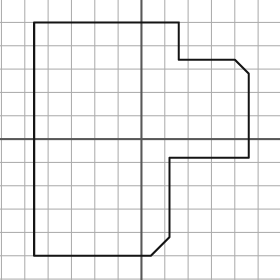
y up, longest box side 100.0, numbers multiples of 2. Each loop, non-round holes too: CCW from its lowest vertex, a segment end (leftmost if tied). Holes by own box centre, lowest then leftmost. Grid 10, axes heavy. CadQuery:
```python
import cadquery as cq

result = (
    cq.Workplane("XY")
    .moveTo(-46.0, -50.0)
    .lineTo(4.0, -50.0)
    .lineTo(12.0, -42.0)
    .lineTo(12.0, -8.0)
    .lineTo(46.0, -8.0)
    .lineTo(46.0, 28.0)
    .lineTo(40.0, 34.0)
    .lineTo(16.0, 34.0)
    .lineTo(16.0, 50.0)
    .lineTo(-46.0, 50.0)
    .close()
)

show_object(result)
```